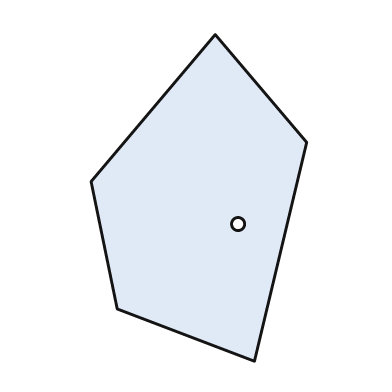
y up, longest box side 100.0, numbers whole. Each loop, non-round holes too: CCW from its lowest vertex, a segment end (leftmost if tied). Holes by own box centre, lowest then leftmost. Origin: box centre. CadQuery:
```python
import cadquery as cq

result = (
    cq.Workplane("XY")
    .moveTo(17.0, -50.0)
    .lineTo(33.0, 17.0)
    .lineTo(5.0, 50.0)
    .lineTo(-33.0, 5.0)
    .lineTo(-25.0, -34.0)
    .close()
    .moveTo(12.0, -8.0)
    .circle(2.0)
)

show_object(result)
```